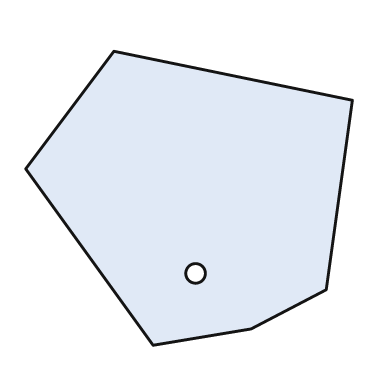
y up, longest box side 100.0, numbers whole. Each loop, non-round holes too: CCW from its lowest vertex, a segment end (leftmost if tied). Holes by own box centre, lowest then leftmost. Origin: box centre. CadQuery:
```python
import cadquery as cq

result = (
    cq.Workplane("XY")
    .moveTo(-11.0, -45.0)
    .lineTo(19.0, -40.0)
    .lineTo(42.0, -28.0)
    .lineTo(50.0, 30.0)
    .lineTo(-23.0, 45.0)
    .lineTo(-50.0, 9.0)
    .close()
    .moveTo(2.0, -23.0)
    .circle(3.0)
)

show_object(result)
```